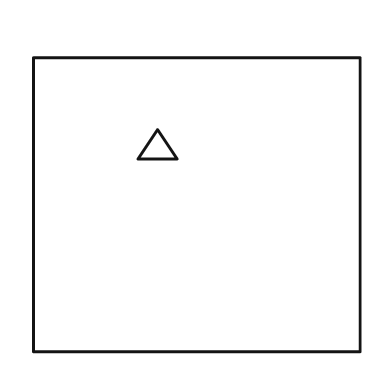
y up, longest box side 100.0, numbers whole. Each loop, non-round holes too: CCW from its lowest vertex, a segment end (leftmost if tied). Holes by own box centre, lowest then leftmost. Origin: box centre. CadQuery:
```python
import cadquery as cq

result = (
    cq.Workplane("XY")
    .moveTo(-50.0, -45.0)
    .lineTo(50.0, -45.0)
    .lineTo(50.0, 45.0)
    .lineTo(-50.0, 45.0)
    .close()
    .moveTo(-18.0, 14.0)
    .lineTo(-6.0, 14.0)
    .lineTo(-12.0, 23.0)
    .close()
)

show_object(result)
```